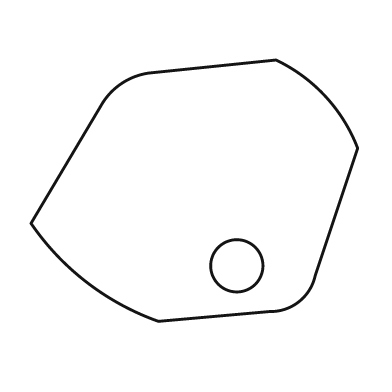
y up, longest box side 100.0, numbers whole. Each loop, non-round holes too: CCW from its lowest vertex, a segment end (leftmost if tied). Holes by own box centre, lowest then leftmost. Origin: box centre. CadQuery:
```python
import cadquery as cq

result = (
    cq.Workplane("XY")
    .moveTo(-11.0, -40.0)
    .lineTo(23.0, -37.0)
    .threePointArc((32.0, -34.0), (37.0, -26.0))
    .lineTo(50.0, 13.0)
    .threePointArc((40.0, 29.0), (25.0, 40.0))
    .lineTo(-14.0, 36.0)
    .threePointArc((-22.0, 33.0), (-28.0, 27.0))
    .lineTo(-50.0, -10.0)
    .threePointArc((-33.0, -28.0), (-11.0, -40.0))
    .close()
    .moveTo(13.0, -23.0)
    .circle(8.0)
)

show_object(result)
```